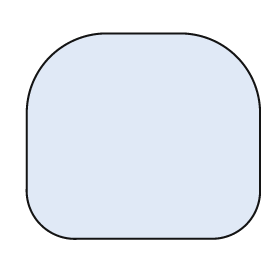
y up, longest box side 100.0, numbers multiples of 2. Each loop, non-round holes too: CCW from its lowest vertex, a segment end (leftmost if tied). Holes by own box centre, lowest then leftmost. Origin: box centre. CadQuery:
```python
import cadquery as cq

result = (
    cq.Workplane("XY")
    .moveTo(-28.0, -44.0)
    .lineTo(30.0, -44.0)
    .threePointArc((44.0, -38.0), (50.0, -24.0))
    .lineTo(50.0, 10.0)
    .threePointArc((40.0, 34.0), (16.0, 44.0))
    .lineTo(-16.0, 44.0)
    .threePointArc((-40.0, 34.0), (-50.0, 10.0))
    .lineTo(-50.0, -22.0)
    .threePointArc((-44.0, -38.0), (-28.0, -44.0))
    .close()
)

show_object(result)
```